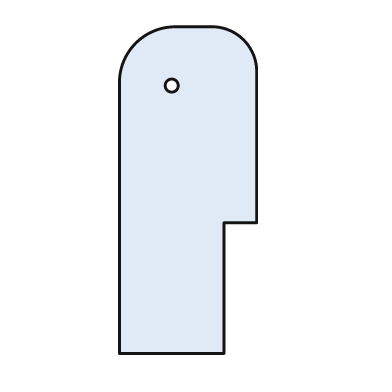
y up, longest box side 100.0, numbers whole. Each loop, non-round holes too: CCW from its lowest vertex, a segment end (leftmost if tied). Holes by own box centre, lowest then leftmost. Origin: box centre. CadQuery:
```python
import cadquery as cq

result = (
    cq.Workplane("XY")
    .moveTo(-21.0, -50.0)
    .lineTo(11.0, -50.0)
    .lineTo(11.0, -10.0)
    .lineTo(21.0, -10.0)
    .lineTo(21.0, 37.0)
    .threePointArc((17.0, 46.0), (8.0, 50.0))
    .lineTo(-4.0, 50.0)
    .threePointArc((-16.0, 45.0), (-21.0, 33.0))
    .close()
    .moveTo(-5.0, 32.0)
    .circle(2.0)
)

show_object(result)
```